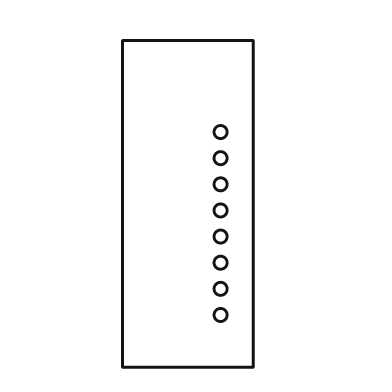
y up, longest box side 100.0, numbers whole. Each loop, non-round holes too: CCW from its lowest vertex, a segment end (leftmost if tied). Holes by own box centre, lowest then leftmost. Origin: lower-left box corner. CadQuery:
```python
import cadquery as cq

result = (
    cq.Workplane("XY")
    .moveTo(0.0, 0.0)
    .lineTo(40.0, 0.0)
    .lineTo(40.0, 100.0)
    .lineTo(0.0, 100.0)
    .close()
    .moveTo(30.0, 16.0)
    .circle(2.0)
    .moveTo(30.0, 24.0)
    .circle(2.0)
    .moveTo(30.0, 32.0)
    .circle(2.0)
    .moveTo(30.0, 40.0)
    .circle(2.0)
    .moveTo(30.0, 48.0)
    .circle(2.0)
    .moveTo(30.0, 56.0)
    .circle(2.0)
    .moveTo(30.0, 64.0)
    .circle(2.0)
    .moveTo(30.0, 72.0)
    .circle(2.0)
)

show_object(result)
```